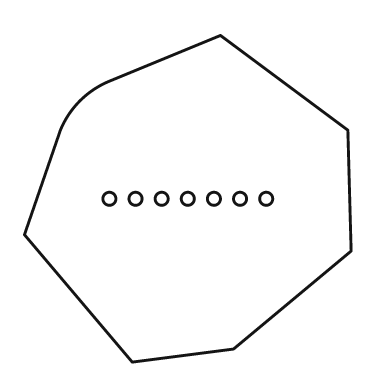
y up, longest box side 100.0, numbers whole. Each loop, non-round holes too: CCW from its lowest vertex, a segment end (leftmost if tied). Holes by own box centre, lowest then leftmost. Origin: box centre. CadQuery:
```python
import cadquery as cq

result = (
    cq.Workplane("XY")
    .moveTo(-17.0, -50.0)
    .lineTo(14.0, -46.0)
    .lineTo(50.0, -16.0)
    .lineTo(49.0, 21.0)
    .lineTo(10.0, 50.0)
    .lineTo(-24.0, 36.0)
    .threePointArc((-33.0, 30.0), (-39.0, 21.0))
    .lineTo(-50.0, -11.0)
    .close()
    .moveTo(-24.0, 0.0)
    .circle(2.0)
    .moveTo(-16.0, 0.0)
    .circle(2.0)
    .moveTo(-8.0, 0.0)
    .circle(2.0)
    .moveTo(0.0, 0.0)
    .circle(2.0)
    .moveTo(8.0, 0.0)
    .circle(2.0)
    .moveTo(16.0, 0.0)
    .circle(2.0)
    .moveTo(24.0, 0.0)
    .circle(2.0)
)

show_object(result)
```